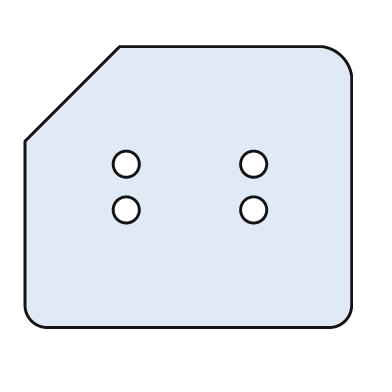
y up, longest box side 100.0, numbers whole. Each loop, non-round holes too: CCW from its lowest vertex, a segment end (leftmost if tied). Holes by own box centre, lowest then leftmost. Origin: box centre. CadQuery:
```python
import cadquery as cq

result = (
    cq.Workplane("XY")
    .moveTo(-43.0, -43.0)
    .lineTo(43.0, -43.0)
    .threePointArc((48.0, -41.0), (50.0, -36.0))
    .lineTo(50.0, 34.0)
    .threePointArc((47.0, 40.0), (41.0, 43.0))
    .lineTo(-21.0, 43.0)
    .lineTo(-50.0, 14.0)
    .lineTo(-50.0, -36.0)
    .threePointArc((-48.0, -41.0), (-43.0, -43.0))
    .close()
    .moveTo(-19.0, -7.0)
    .circle(4.0)
    .moveTo(20.0, -7.0)
    .circle(4.0)
    .moveTo(-19.0, 7.0)
    .circle(4.0)
    .moveTo(20.0, 7.0)
    .circle(4.0)
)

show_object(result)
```